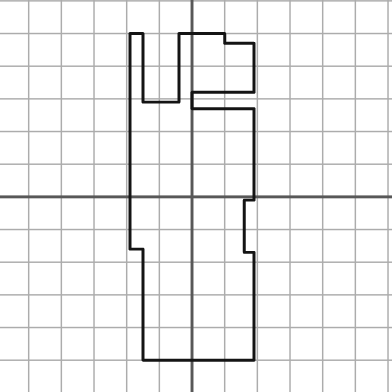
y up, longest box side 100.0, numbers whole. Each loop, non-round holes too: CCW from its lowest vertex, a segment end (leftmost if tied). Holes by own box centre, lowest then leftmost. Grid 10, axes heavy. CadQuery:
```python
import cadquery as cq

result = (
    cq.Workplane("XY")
    .moveTo(-15.0, -50.0)
    .lineTo(19.0, -50.0)
    .lineTo(19.0, -17.0)
    .lineTo(16.0, -17.0)
    .lineTo(16.0, -1.0)
    .lineTo(19.0, -1.0)
    .lineTo(19.0, 27.0)
    .lineTo(0.0, 27.0)
    .lineTo(0.0, 32.0)
    .lineTo(19.0, 32.0)
    .lineTo(19.0, 47.0)
    .lineTo(10.0, 47.0)
    .lineTo(10.0, 50.0)
    .lineTo(-4.0, 50.0)
    .lineTo(-4.0, 29.0)
    .lineTo(-15.0, 29.0)
    .lineTo(-15.0, 50.0)
    .lineTo(-19.0, 50.0)
    .lineTo(-19.0, -16.0)
    .lineTo(-15.0, -16.0)
    .close()
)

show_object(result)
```